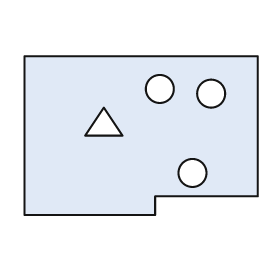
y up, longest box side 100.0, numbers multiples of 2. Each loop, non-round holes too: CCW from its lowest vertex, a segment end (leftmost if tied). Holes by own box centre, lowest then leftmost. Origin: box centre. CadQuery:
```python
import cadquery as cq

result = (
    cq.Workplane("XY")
    .moveTo(-50.0, -34.0)
    .lineTo(6.0, -34.0)
    .lineTo(6.0, -26.0)
    .lineTo(50.0, -26.0)
    .lineTo(50.0, 34.0)
    .lineTo(-50.0, 34.0)
    .close()
    .moveTo(22.0, -16.0)
    .circle(6.0)
    .moveTo(-24.0, 0.0)
    .lineTo(-8.0, 0.0)
    .lineTo(-16.0, 12.0)
    .close()
    .moveTo(30.0, 18.0)
    .circle(6.0)
    .moveTo(8.0, 20.0)
    .circle(6.0)
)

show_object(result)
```